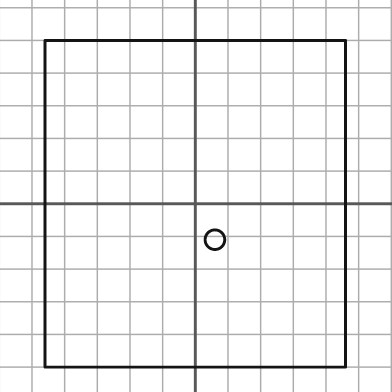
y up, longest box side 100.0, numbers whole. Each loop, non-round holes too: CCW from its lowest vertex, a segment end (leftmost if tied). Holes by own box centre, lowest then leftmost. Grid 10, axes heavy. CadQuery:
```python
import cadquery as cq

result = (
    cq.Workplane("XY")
    .moveTo(-46.0, -50.0)
    .lineTo(46.0, -50.0)
    .lineTo(46.0, 50.0)
    .lineTo(-46.0, 50.0)
    .close()
    .moveTo(6.0, -11.0)
    .circle(3.0)
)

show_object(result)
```